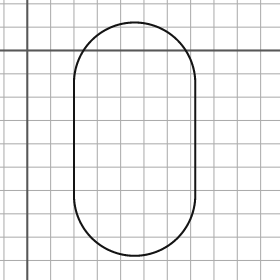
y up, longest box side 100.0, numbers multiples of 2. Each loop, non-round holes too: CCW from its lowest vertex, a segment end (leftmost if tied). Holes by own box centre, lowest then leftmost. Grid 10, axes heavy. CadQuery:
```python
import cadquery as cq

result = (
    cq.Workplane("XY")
    .moveTo(20.0, -62.0)
    .threePointArc((46.0, -88.0), (72.0, -62.0))
    .lineTo(72.0, -14.0)
    .threePointArc((46.0, 12.0), (20.0, -14.0))
    .close()
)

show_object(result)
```